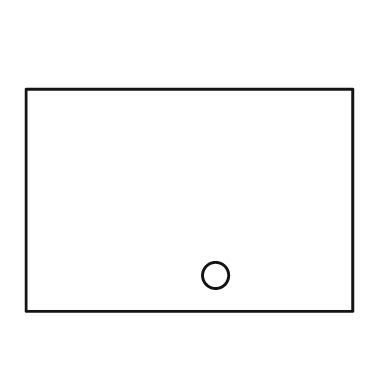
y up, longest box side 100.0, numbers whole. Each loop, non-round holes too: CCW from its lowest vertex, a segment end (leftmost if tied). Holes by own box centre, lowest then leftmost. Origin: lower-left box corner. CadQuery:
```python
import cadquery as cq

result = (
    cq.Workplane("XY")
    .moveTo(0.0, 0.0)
    .lineTo(100.0, 0.0)
    .lineTo(100.0, 68.0)
    .lineTo(0.0, 68.0)
    .close()
    .moveTo(58.0, 11.0)
    .circle(4.0)
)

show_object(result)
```